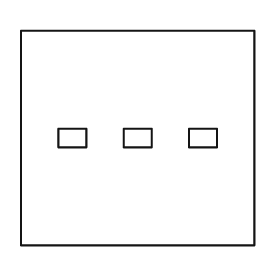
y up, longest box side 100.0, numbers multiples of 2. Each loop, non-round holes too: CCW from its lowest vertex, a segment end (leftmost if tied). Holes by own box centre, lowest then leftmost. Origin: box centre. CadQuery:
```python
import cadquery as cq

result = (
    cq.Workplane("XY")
    .moveTo(-50.0, -46.0)
    .lineTo(50.0, -46.0)
    .lineTo(50.0, 46.0)
    .lineTo(-50.0, 46.0)
    .close()
    .moveTo(-34.0, -4.0)
    .lineTo(-22.0, -4.0)
    .lineTo(-22.0, 4.0)
    .lineTo(-34.0, 4.0)
    .close()
    .moveTo(-6.0, -4.0)
    .lineTo(6.0, -4.0)
    .lineTo(6.0, 4.0)
    .lineTo(-6.0, 4.0)
    .close()
    .moveTo(22.0, -4.0)
    .lineTo(34.0, -4.0)
    .lineTo(34.0, 4.0)
    .lineTo(22.0, 4.0)
    .close()
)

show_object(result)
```